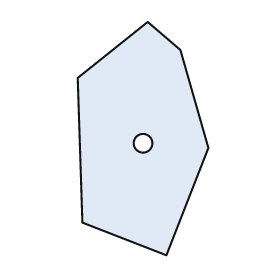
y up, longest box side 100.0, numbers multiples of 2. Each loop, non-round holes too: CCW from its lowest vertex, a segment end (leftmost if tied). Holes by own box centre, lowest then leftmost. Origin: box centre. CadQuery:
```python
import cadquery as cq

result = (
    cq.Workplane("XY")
    .moveTo(10.0, -50.0)
    .lineTo(28.0, -4.0)
    .lineTo(16.0, 38.0)
    .lineTo(2.0, 50.0)
    .lineTo(-28.0, 26.0)
    .lineTo(-26.0, -36.0)
    .close()
    .moveTo(0.0, -2.0)
    .circle(4.0)
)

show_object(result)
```